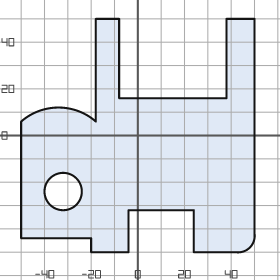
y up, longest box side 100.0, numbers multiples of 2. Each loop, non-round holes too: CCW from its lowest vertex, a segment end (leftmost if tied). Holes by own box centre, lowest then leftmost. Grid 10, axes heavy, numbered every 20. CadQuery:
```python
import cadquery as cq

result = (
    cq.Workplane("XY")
    .moveTo(-20.0, -50.0)
    .lineTo(-4.0, -50.0)
    .lineTo(-4.0, -32.0)
    .lineTo(24.0, -32.0)
    .lineTo(24.0, -50.0)
    .lineTo(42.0, -50.0)
    .threePointArc((48.0, -48.0), (50.0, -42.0))
    .lineTo(50.0, 50.0)
    .lineTo(38.0, 50.0)
    .lineTo(38.0, 16.0)
    .lineTo(-8.0, 16.0)
    .lineTo(-8.0, 50.0)
    .lineTo(-18.0, 50.0)
    .lineTo(-18.0, 6.0)
    .threePointArc((-34.0, 12.0), (-50.0, 6.0))
    .lineTo(-50.0, -44.0)
    .lineTo(-20.0, -44.0)
    .close()
    .moveTo(-32.0, -24.0)
    .circle(8.0)
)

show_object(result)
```